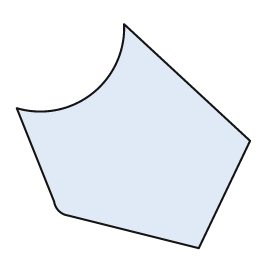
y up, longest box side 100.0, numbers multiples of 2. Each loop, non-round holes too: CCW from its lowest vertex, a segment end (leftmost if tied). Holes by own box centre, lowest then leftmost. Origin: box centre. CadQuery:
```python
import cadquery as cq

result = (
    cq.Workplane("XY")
    .moveTo(28.0, -48.0)
    .lineTo(50.0, -2.0)
    .lineTo(-4.0, 48.0)
    .threePointArc((-18.0, 18.0), (-50.0, 12.0))
    .lineTo(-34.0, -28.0)
    .threePointArc((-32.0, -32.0), (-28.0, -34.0))
    .close()
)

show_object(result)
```